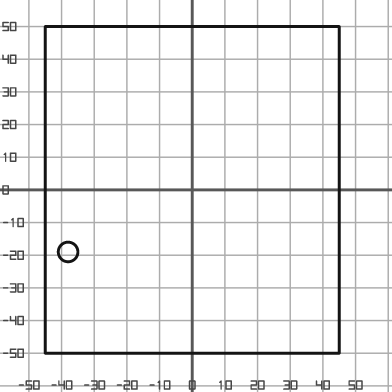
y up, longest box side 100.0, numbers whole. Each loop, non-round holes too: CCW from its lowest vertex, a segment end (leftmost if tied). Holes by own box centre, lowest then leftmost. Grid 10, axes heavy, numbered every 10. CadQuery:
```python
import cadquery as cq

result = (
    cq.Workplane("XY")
    .moveTo(-45.0, -50.0)
    .lineTo(45.0, -50.0)
    .lineTo(45.0, 50.0)
    .lineTo(-45.0, 50.0)
    .close()
    .moveTo(-38.0, -19.0)
    .circle(3.0)
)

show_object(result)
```